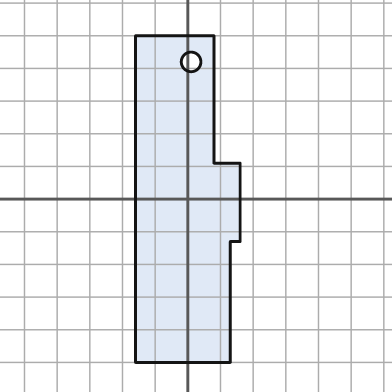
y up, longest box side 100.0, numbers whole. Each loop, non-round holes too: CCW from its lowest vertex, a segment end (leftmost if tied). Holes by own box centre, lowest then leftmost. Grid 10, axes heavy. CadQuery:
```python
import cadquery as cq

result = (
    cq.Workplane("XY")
    .moveTo(-16.0, -50.0)
    .lineTo(13.0, -50.0)
    .lineTo(13.0, -13.0)
    .lineTo(16.0, -13.0)
    .lineTo(16.0, 11.0)
    .lineTo(8.0, 11.0)
    .lineTo(8.0, 50.0)
    .lineTo(-16.0, 50.0)
    .close()
    .moveTo(1.0, 42.0)
    .circle(3.0)
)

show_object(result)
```